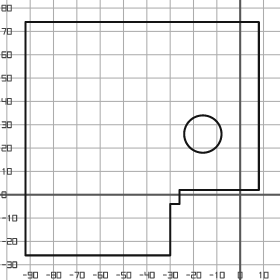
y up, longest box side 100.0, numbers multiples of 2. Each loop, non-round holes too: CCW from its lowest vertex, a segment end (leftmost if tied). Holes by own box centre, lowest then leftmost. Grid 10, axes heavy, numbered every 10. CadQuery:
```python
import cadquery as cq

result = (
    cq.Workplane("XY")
    .moveTo(-92.0, -26.0)
    .lineTo(-30.0, -26.0)
    .lineTo(-30.0, -4.0)
    .lineTo(-26.0, -4.0)
    .lineTo(-26.0, 2.0)
    .lineTo(8.0, 2.0)
    .lineTo(8.0, 74.0)
    .lineTo(-92.0, 74.0)
    .close()
    .moveTo(-16.0, 26.0)
    .circle(8.0)
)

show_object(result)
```